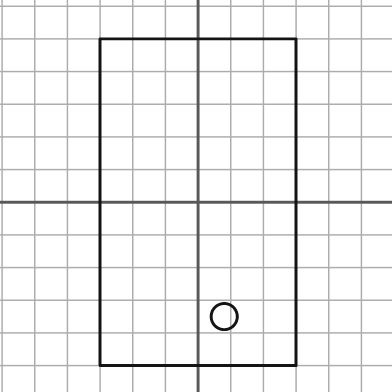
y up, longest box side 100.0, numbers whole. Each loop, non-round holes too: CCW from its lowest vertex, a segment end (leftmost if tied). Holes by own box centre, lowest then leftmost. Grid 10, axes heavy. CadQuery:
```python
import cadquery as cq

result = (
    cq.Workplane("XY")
    .moveTo(-30.0, -50.0)
    .lineTo(30.0, -50.0)
    .lineTo(30.0, 50.0)
    .lineTo(-30.0, 50.0)
    .close()
    .moveTo(8.0, -35.0)
    .circle(4.0)
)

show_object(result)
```